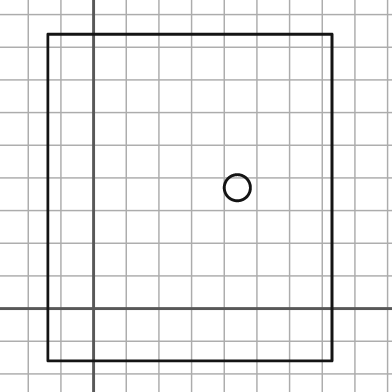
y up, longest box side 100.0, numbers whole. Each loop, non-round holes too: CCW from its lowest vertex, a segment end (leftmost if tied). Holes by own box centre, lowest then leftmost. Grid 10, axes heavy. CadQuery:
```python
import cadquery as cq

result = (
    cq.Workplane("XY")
    .moveTo(-14.0, -16.0)
    .lineTo(73.0, -16.0)
    .lineTo(73.0, 84.0)
    .lineTo(-14.0, 84.0)
    .close()
    .moveTo(44.0, 37.0)
    .circle(4.0)
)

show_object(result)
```